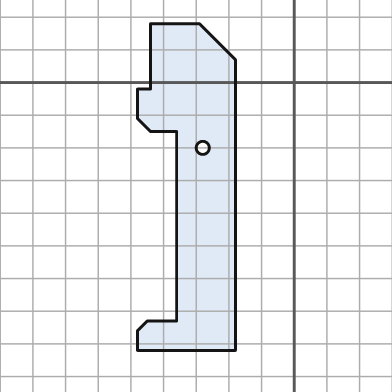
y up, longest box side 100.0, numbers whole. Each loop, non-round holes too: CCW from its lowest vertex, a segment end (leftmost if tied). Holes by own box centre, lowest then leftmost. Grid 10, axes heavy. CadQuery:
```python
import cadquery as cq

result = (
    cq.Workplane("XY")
    .moveTo(-48.0, -82.0)
    .lineTo(-18.0, -82.0)
    .lineTo(-18.0, 7.0)
    .lineTo(-29.0, 18.0)
    .lineTo(-44.0, 18.0)
    .lineTo(-44.0, -2.0)
    .lineTo(-48.0, -2.0)
    .lineTo(-48.0, -11.0)
    .lineTo(-44.0, -15.0)
    .lineTo(-36.0, -15.0)
    .lineTo(-36.0, -73.0)
    .lineTo(-45.0, -73.0)
    .lineTo(-48.0, -76.0)
    .close()
    .moveTo(-28.0, -20.0)
    .circle(2.0)
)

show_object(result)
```